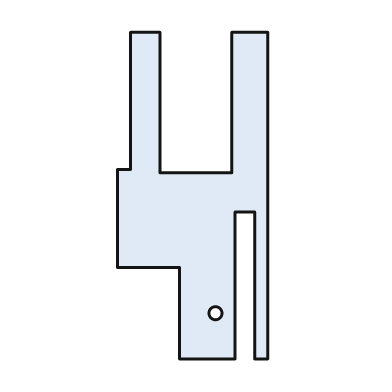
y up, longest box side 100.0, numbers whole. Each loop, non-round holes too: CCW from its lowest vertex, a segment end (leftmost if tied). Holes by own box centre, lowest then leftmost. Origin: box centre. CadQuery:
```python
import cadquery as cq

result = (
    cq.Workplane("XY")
    .moveTo(-4.0, -50.0)
    .lineTo(13.0, -50.0)
    .lineTo(13.0, -5.0)
    .lineTo(19.0, -5.0)
    .lineTo(19.0, -50.0)
    .lineTo(23.0, -50.0)
    .lineTo(23.0, 50.0)
    .lineTo(12.0, 50.0)
    .lineTo(12.0, 7.0)
    .lineTo(-10.0, 7.0)
    .lineTo(-10.0, 50.0)
    .lineTo(-19.0, 50.0)
    .lineTo(-19.0, 8.0)
    .lineTo(-23.0, 8.0)
    .lineTo(-23.0, -22.0)
    .lineTo(-4.0, -22.0)
    .close()
    .moveTo(7.0, -36.0)
    .circle(2.0)
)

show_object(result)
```